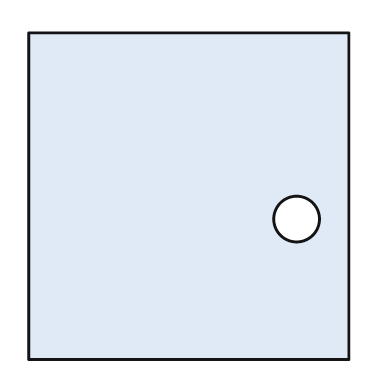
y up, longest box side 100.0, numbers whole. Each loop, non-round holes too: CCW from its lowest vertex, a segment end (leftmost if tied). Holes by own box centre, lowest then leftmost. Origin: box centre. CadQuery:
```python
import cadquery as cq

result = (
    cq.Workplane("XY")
    .moveTo(-49.0, -50.0)
    .lineTo(49.0, -50.0)
    .lineTo(49.0, 50.0)
    .lineTo(-49.0, 50.0)
    .close()
    .moveTo(33.0, -7.0)
    .circle(7.0)
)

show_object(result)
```